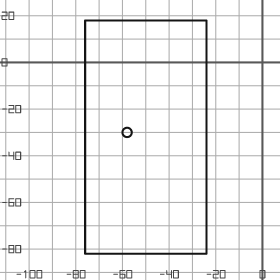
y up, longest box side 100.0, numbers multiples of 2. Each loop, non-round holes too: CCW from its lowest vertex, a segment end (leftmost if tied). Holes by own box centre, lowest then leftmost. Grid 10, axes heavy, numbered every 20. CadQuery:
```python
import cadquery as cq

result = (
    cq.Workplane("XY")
    .moveTo(-76.0, -82.0)
    .lineTo(-24.0, -82.0)
    .lineTo(-24.0, 18.0)
    .lineTo(-76.0, 18.0)
    .close()
    .moveTo(-58.0, -30.0)
    .circle(2.0)
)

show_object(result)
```